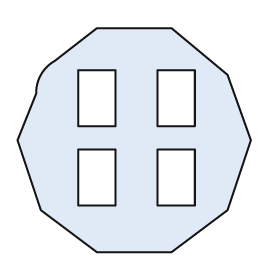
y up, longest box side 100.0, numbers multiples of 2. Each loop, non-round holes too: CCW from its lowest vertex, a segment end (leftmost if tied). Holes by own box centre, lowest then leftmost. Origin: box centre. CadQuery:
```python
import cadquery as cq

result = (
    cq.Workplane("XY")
    .moveTo(-16.0, -48.0)
    .lineTo(16.0, -48.0)
    .lineTo(40.0, -30.0)
    .lineTo(50.0, 0.0)
    .lineTo(40.0, 28.0)
    .lineTo(16.0, 48.0)
    .lineTo(-16.0, 48.0)
    .lineTo(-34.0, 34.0)
    .threePointArc((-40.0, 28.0), (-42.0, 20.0))
    .lineTo(-50.0, 0.0)
    .lineTo(-40.0, -30.0)
    .close()
    .moveTo(-24.0, -28.0)
    .lineTo(-8.0, -28.0)
    .lineTo(-8.0, -4.0)
    .lineTo(-24.0, -4.0)
    .close()
    .moveTo(10.0, -28.0)
    .lineTo(26.0, -28.0)
    .lineTo(26.0, -4.0)
    .lineTo(10.0, -4.0)
    .close()
    .moveTo(-24.0, 6.0)
    .lineTo(-8.0, 6.0)
    .lineTo(-8.0, 30.0)
    .lineTo(-24.0, 30.0)
    .close()
    .moveTo(10.0, 6.0)
    .lineTo(26.0, 6.0)
    .lineTo(26.0, 30.0)
    .lineTo(10.0, 30.0)
    .close()
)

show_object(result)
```